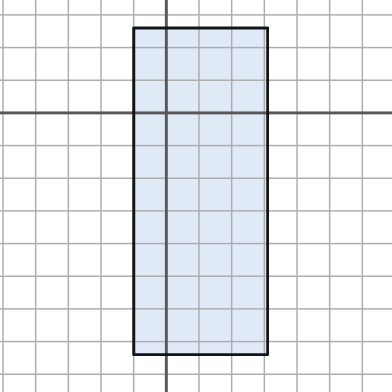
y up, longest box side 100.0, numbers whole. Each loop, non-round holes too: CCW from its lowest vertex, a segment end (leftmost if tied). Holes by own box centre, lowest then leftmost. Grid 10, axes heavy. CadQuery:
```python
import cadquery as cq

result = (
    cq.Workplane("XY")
    .moveTo(-10.0, -74.0)
    .lineTo(31.0, -74.0)
    .lineTo(31.0, 26.0)
    .lineTo(-10.0, 26.0)
    .close()
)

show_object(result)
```